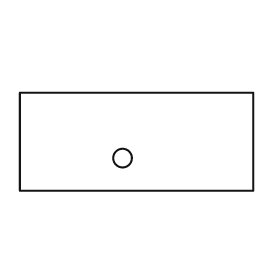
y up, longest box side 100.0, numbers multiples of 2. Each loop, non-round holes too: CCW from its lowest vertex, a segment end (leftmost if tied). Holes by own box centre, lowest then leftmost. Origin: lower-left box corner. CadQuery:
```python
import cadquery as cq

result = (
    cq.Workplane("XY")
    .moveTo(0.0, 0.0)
    .lineTo(100.0, 0.0)
    .lineTo(100.0, 42.0)
    .lineTo(0.0, 42.0)
    .close()
    .moveTo(44.0, 14.0)
    .circle(4.0)
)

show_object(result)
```